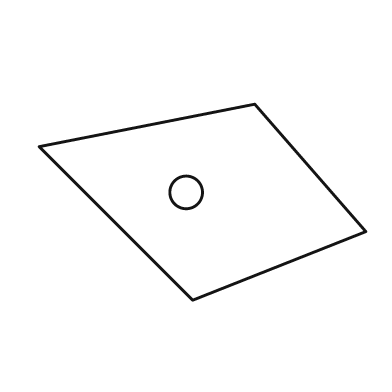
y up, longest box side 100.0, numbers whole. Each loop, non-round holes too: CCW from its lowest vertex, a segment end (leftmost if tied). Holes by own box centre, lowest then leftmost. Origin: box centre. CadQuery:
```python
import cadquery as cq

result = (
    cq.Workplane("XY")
    .moveTo(-3.0, -30.0)
    .lineTo(50.0, -9.0)
    .lineTo(16.0, 30.0)
    .lineTo(-50.0, 17.0)
    .close()
    .moveTo(-5.0, 3.0)
    .circle(5.0)
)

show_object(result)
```